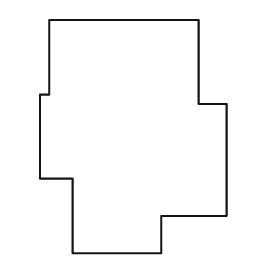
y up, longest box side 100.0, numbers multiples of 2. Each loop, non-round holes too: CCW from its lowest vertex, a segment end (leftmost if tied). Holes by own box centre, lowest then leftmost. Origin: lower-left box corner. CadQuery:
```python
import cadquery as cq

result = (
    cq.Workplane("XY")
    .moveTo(14.0, 0.0)
    .lineTo(52.0, 0.0)
    .lineTo(52.0, 16.0)
    .lineTo(80.0, 16.0)
    .lineTo(80.0, 64.0)
    .lineTo(68.0, 64.0)
    .lineTo(68.0, 100.0)
    .lineTo(4.0, 100.0)
    .lineTo(4.0, 68.0)
    .lineTo(0.0, 68.0)
    .lineTo(0.0, 32.0)
    .lineTo(14.0, 32.0)
    .close()
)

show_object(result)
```